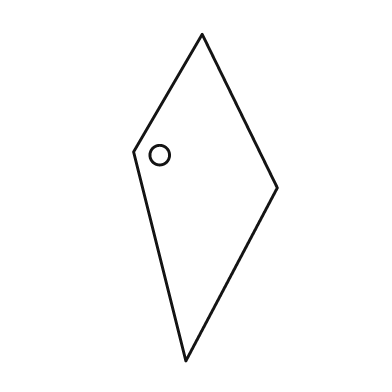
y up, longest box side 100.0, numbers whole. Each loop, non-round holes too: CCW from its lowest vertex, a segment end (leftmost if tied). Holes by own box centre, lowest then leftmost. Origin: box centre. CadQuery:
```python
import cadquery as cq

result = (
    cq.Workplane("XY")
    .moveTo(-6.0, -50.0)
    .lineTo(22.0, 3.0)
    .lineTo(-1.0, 50.0)
    .lineTo(-22.0, 14.0)
    .close()
    .moveTo(-14.0, 13.0)
    .circle(3.0)
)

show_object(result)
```